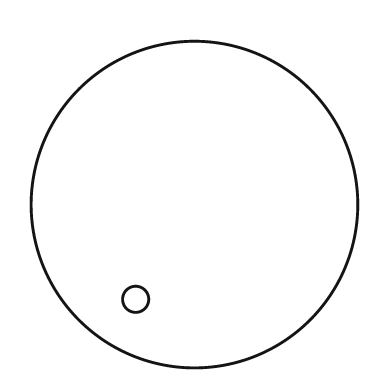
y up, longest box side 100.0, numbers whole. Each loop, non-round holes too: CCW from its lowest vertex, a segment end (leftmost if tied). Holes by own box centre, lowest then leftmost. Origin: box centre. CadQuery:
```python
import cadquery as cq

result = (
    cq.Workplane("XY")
    .moveTo(0.0, 0.0)
    .circle(50.0)
    .moveTo(-18.0, -29.0)
    .circle(4.0)
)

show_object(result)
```